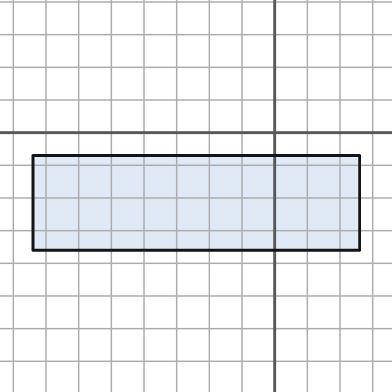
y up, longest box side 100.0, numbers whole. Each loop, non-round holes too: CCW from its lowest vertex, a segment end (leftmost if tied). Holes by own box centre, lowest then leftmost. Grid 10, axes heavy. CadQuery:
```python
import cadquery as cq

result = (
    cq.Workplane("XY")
    .moveTo(-74.0, -36.0)
    .lineTo(26.0, -36.0)
    .lineTo(26.0, -7.0)
    .lineTo(-74.0, -7.0)
    .close()
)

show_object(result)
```